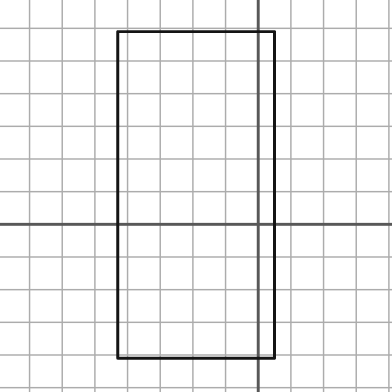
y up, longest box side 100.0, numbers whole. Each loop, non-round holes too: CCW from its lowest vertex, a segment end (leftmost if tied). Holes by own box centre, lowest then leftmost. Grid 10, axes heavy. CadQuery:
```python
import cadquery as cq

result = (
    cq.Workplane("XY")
    .moveTo(-43.0, -41.0)
    .lineTo(5.0, -41.0)
    .lineTo(5.0, 59.0)
    .lineTo(-43.0, 59.0)
    .close()
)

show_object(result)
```